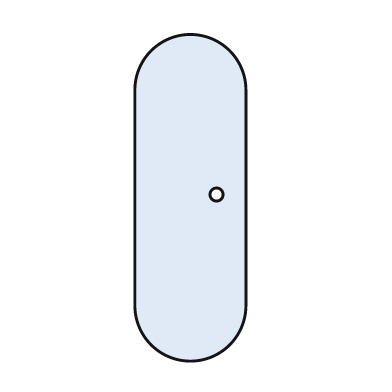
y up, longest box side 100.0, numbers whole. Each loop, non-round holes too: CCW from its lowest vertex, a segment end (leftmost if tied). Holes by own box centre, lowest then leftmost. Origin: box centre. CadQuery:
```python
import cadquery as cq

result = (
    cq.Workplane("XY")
    .moveTo(-17.0, -33.0)
    .threePointArc((0.0, -50.0), (17.0, -33.0))
    .lineTo(17.0, 33.0)
    .threePointArc((0.0, 50.0), (-17.0, 33.0))
    .close()
    .moveTo(8.0, 1.0)
    .circle(2.0)
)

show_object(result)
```